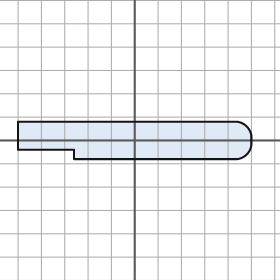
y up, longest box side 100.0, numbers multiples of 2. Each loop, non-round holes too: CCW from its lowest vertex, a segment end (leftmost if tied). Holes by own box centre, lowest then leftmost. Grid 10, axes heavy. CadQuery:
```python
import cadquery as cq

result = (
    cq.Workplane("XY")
    .moveTo(-26.0, -8.0)
    .lineTo(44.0, -8.0)
    .threePointArc((48.0, -6.0), (50.0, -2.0))
    .lineTo(50.0, 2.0)
    .threePointArc((48.0, 6.0), (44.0, 8.0))
    .lineTo(-50.0, 8.0)
    .lineTo(-50.0, -4.0)
    .lineTo(-26.0, -4.0)
    .close()
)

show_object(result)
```